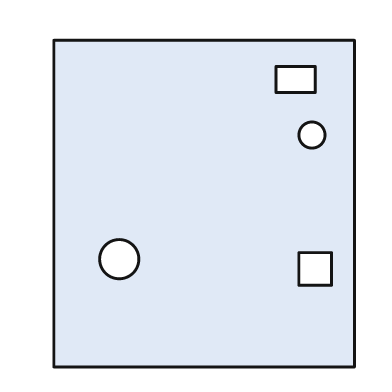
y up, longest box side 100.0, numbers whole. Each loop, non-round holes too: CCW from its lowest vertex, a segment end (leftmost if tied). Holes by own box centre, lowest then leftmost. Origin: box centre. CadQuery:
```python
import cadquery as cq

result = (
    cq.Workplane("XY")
    .moveTo(-46.0, -50.0)
    .lineTo(46.0, -50.0)
    .lineTo(46.0, 50.0)
    .lineTo(-46.0, 50.0)
    .close()
    .moveTo(29.0, -25.0)
    .lineTo(39.0, -25.0)
    .lineTo(39.0, -15.0)
    .lineTo(29.0, -15.0)
    .close()
    .moveTo(-26.0, -17.0)
    .circle(6.0)
    .moveTo(33.0, 21.0)
    .circle(4.0)
    .moveTo(22.0, 34.0)
    .lineTo(34.0, 34.0)
    .lineTo(34.0, 42.0)
    .lineTo(22.0, 42.0)
    .close()
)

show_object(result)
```